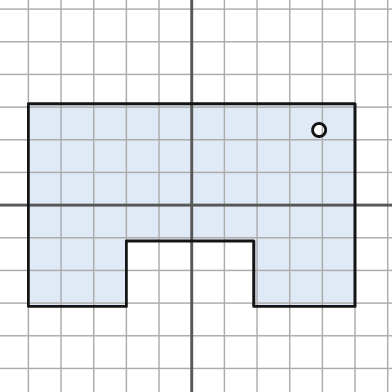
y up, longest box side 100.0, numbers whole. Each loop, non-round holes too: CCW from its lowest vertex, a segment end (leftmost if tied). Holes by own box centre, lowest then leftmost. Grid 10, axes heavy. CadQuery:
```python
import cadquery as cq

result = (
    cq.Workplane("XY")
    .moveTo(-50.0, -31.0)
    .lineTo(-20.0, -31.0)
    .lineTo(-20.0, -11.0)
    .lineTo(19.0, -11.0)
    .lineTo(19.0, -31.0)
    .lineTo(50.0, -31.0)
    .lineTo(50.0, 31.0)
    .lineTo(-50.0, 31.0)
    .close()
    .moveTo(39.0, 23.0)
    .circle(2.0)
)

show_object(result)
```